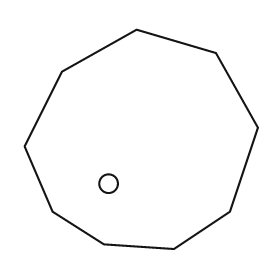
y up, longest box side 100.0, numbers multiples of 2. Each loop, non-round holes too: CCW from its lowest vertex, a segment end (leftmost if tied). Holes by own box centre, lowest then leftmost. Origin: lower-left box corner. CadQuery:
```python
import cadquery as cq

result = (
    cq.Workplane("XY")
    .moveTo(64.0, 0.0)
    .lineTo(88.0, 16.0)
    .lineTo(100.0, 52.0)
    .lineTo(82.0, 84.0)
    .lineTo(48.0, 94.0)
    .lineTo(16.0, 76.0)
    .lineTo(0.0, 44.0)
    .lineTo(12.0, 16.0)
    .lineTo(34.0, 2.0)
    .close()
    .moveTo(36.0, 28.0)
    .circle(4.0)
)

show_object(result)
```